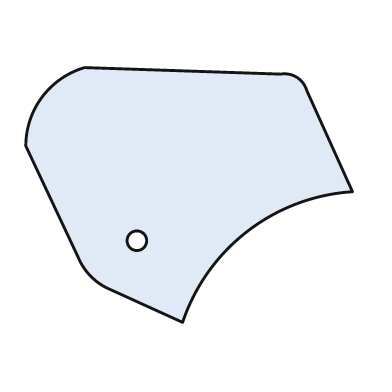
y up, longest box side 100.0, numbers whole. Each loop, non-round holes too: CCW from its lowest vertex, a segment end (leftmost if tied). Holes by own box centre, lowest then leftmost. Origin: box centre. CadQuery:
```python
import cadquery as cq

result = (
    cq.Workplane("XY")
    .moveTo(-2.0, -39.0)
    .threePointArc((18.0, -11.0), (50.0, 1.0))
    .lineTo(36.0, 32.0)
    .threePointArc((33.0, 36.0), (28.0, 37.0))
    .lineTo(-32.0, 39.0)
    .threePointArc((-45.0, 30.0), (-50.0, 15.0))
    .lineTo(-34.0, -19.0)
    .threePointArc((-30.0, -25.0), (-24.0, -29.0))
    .close()
    .moveTo(-16.0, -14.0)
    .circle(3.0)
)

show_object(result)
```